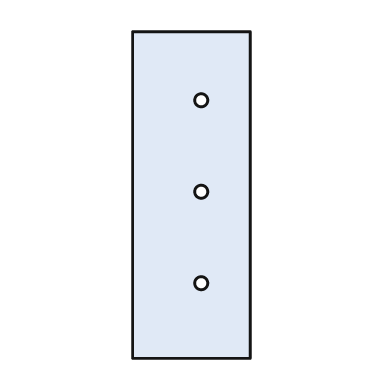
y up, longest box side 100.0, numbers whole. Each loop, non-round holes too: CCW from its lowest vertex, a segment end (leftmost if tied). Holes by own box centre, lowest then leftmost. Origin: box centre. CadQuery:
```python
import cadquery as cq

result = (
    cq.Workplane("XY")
    .moveTo(-18.0, -50.0)
    .lineTo(18.0, -50.0)
    .lineTo(18.0, 50.0)
    .lineTo(-18.0, 50.0)
    .close()
    .moveTo(3.0, -27.0)
    .circle(2.0)
    .moveTo(3.0, 1.0)
    .circle(2.0)
    .moveTo(3.0, 29.0)
    .circle(2.0)
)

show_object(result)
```